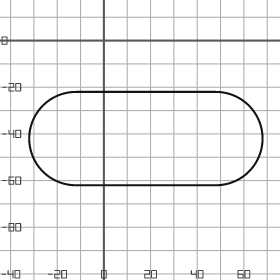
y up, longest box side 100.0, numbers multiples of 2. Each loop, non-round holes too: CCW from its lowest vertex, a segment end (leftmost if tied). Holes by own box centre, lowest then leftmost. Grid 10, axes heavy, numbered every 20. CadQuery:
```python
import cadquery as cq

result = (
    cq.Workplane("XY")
    .moveTo(-12.0, -62.0)
    .lineTo(48.0, -62.0)
    .threePointArc((68.0, -42.0), (48.0, -22.0))
    .lineTo(-12.0, -22.0)
    .threePointArc((-32.0, -42.0), (-12.0, -62.0))
    .close()
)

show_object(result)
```